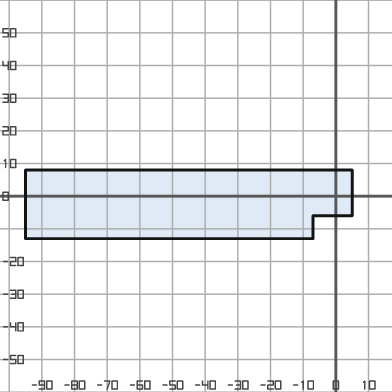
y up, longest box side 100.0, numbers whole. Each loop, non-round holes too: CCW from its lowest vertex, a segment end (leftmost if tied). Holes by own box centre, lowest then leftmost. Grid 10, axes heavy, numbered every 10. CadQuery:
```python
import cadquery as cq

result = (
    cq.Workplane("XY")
    .moveTo(-95.0, -13.0)
    .lineTo(-7.0, -13.0)
    .lineTo(-7.0, -6.0)
    .lineTo(5.0, -6.0)
    .lineTo(5.0, 8.0)
    .lineTo(-95.0, 8.0)
    .close()
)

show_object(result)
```